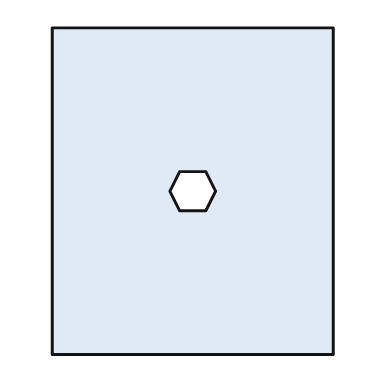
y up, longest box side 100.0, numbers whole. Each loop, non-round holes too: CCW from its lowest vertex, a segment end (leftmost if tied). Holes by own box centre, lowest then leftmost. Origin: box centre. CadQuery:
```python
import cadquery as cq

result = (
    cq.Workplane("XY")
    .moveTo(-43.0, -50.0)
    .lineTo(43.0, -50.0)
    .lineTo(43.0, 50.0)
    .lineTo(-43.0, 50.0)
    .close()
    .moveTo(-4.0, -6.0)
    .lineTo(4.0, -6.0)
    .lineTo(7.0, 0.0)
    .lineTo(4.0, 6.0)
    .lineTo(-4.0, 6.0)
    .lineTo(-7.0, 0.0)
    .close()
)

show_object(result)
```